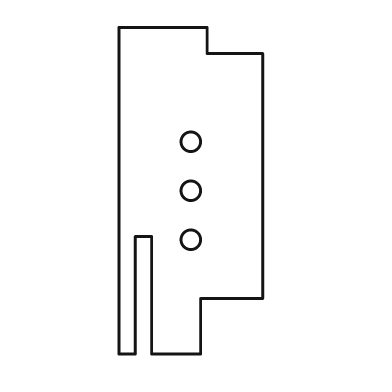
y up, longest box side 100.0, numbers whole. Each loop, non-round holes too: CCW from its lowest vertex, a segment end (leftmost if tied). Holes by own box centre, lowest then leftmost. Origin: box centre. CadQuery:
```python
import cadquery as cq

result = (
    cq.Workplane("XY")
    .moveTo(-22.0, -50.0)
    .lineTo(-17.0, -50.0)
    .lineTo(-17.0, -14.0)
    .lineTo(-12.0, -14.0)
    .lineTo(-12.0, -50.0)
    .lineTo(3.0, -50.0)
    .lineTo(3.0, -33.0)
    .lineTo(22.0, -33.0)
    .lineTo(22.0, 42.0)
    .lineTo(5.0, 42.0)
    .lineTo(5.0, 50.0)
    .lineTo(-22.0, 50.0)
    .close()
    .moveTo(0.0, -15.0)
    .circle(3.0)
    .moveTo(0.0, 0.0)
    .circle(3.0)
    .moveTo(0.0, 15.0)
    .circle(3.0)
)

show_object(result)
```